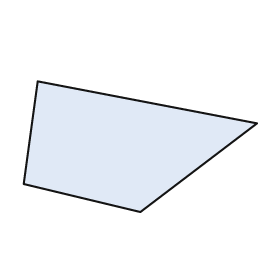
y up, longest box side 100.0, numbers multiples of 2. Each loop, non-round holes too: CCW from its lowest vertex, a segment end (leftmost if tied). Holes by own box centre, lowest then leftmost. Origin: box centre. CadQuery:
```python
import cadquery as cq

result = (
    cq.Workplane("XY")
    .moveTo(0.0, -28.0)
    .lineTo(50.0, 10.0)
    .lineTo(-44.0, 28.0)
    .lineTo(-50.0, -16.0)
    .close()
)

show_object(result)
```